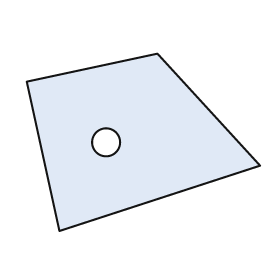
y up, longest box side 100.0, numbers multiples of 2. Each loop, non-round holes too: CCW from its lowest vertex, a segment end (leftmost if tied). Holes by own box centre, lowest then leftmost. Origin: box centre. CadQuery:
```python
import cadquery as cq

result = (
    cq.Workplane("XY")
    .moveTo(-36.0, -38.0)
    .lineTo(50.0, -10.0)
    .lineTo(6.0, 38.0)
    .lineTo(-50.0, 26.0)
    .close()
    .moveTo(-16.0, 0.0)
    .circle(6.0)
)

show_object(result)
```